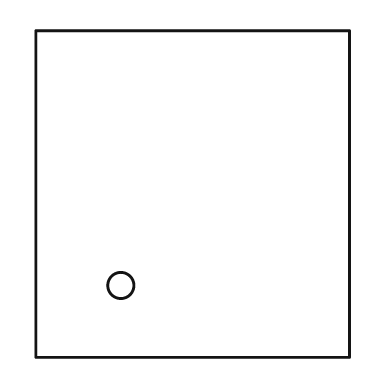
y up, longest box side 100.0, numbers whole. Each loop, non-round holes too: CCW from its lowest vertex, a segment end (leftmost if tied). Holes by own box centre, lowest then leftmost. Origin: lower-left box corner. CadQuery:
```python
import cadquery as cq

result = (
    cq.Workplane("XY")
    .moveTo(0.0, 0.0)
    .lineTo(96.0, 0.0)
    .lineTo(96.0, 100.0)
    .lineTo(0.0, 100.0)
    .close()
    .moveTo(26.0, 22.0)
    .circle(4.0)
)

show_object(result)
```